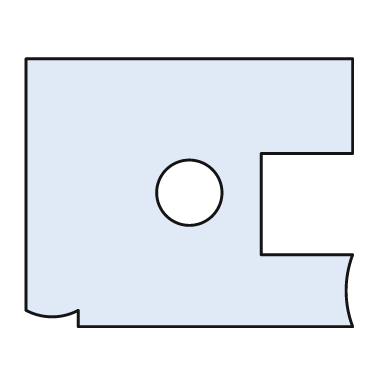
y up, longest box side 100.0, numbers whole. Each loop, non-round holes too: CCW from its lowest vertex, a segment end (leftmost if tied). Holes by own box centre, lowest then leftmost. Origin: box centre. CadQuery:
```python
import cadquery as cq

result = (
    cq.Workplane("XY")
    .moveTo(-34.0, -41.0)
    .lineTo(50.0, -41.0)
    .threePointArc((48.0, -30.0), (50.0, -19.0))
    .lineTo(22.0, -19.0)
    .lineTo(22.0, 12.0)
    .lineTo(50.0, 12.0)
    .lineTo(50.0, 41.0)
    .lineTo(-50.0, 41.0)
    .lineTo(-50.0, -36.0)
    .threePointArc((-42.0, -38.0), (-34.0, -36.0))
    .close()
    .moveTo(0.0, 0.0)
    .circle(10.0)
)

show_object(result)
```